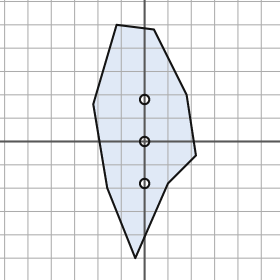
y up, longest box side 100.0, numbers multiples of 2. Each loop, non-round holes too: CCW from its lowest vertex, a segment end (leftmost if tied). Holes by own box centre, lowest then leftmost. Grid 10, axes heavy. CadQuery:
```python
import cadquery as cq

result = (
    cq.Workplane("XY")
    .moveTo(-4.0, -50.0)
    .lineTo(10.0, -18.0)
    .lineTo(22.0, -6.0)
    .lineTo(18.0, 20.0)
    .lineTo(4.0, 48.0)
    .lineTo(-12.0, 50.0)
    .lineTo(-22.0, 16.0)
    .lineTo(-16.0, -20.0)
    .close()
    .moveTo(0.0, -18.0)
    .circle(2.0)
    .moveTo(0.0, 0.0)
    .circle(2.0)
    .moveTo(0.0, 18.0)
    .circle(2.0)
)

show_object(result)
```